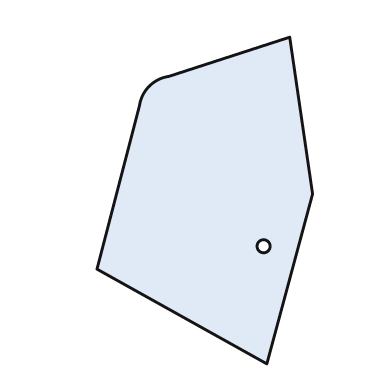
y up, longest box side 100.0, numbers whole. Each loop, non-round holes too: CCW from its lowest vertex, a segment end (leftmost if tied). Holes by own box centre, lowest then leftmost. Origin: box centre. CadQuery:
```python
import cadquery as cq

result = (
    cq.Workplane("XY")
    .moveTo(19.0, -50.0)
    .lineTo(33.0, 2.0)
    .lineTo(26.0, 50.0)
    .lineTo(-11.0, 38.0)
    .threePointArc((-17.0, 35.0), (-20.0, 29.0))
    .lineTo(-33.0, -21.0)
    .close()
    .moveTo(18.0, -14.0)
    .circle(2.0)
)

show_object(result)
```